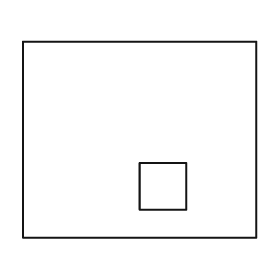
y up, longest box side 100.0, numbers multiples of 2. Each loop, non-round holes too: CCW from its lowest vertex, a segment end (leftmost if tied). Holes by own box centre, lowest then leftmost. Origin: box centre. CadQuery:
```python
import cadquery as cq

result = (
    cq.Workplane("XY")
    .moveTo(-50.0, -42.0)
    .lineTo(50.0, -42.0)
    .lineTo(50.0, 42.0)
    .lineTo(-50.0, 42.0)
    .close()
    .moveTo(0.0, -30.0)
    .lineTo(20.0, -30.0)
    .lineTo(20.0, -10.0)
    .lineTo(0.0, -10.0)
    .close()
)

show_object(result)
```